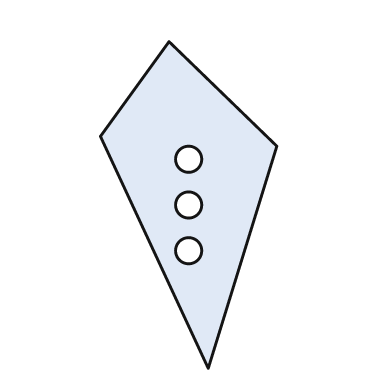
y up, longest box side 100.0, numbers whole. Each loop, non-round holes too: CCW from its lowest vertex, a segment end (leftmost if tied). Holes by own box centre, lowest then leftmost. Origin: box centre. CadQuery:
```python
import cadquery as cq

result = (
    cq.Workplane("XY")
    .moveTo(6.0, -50.0)
    .lineTo(27.0, 18.0)
    .lineTo(-6.0, 50.0)
    .lineTo(-27.0, 21.0)
    .close()
    .moveTo(0.0, -14.0)
    .circle(4.0)
    .moveTo(0.0, 0.0)
    .circle(4.0)
    .moveTo(0.0, 14.0)
    .circle(4.0)
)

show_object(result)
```